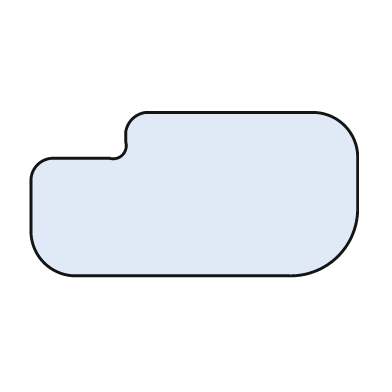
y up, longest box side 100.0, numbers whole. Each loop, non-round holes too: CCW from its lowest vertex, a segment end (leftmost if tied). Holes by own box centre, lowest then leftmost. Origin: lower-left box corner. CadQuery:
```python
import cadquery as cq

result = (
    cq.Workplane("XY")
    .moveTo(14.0, 0.0)
    .lineTo(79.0, 0.0)
    .threePointArc((94.0, 6.0), (100.0, 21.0))
    .lineTo(100.0, 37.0)
    .threePointArc((96.0, 46.0), (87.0, 50.0))
    .lineTo(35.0, 50.0)
    .threePointArc((31.0, 48.0), (29.0, 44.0))
    .lineTo(29.0, 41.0)
    .threePointArc((28.0, 37.0), (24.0, 36.0))
    .lineTo(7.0, 36.0)
    .threePointArc((2.0, 34.0), (0.0, 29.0))
    .lineTo(0.0, 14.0)
    .threePointArc((4.0, 4.0), (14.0, 0.0))
    .close()
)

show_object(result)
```